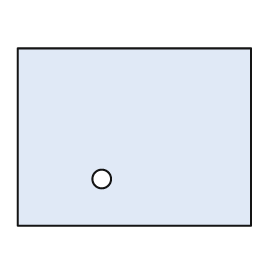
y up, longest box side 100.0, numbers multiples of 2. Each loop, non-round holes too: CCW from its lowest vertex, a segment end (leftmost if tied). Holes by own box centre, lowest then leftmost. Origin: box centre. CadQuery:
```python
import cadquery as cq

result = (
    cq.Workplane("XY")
    .moveTo(-50.0, -38.0)
    .lineTo(50.0, -38.0)
    .lineTo(50.0, 38.0)
    .lineTo(-50.0, 38.0)
    .close()
    .moveTo(-14.0, -18.0)
    .circle(4.0)
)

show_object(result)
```